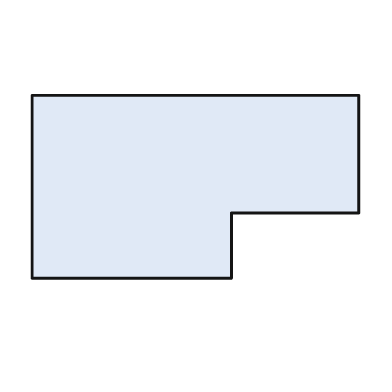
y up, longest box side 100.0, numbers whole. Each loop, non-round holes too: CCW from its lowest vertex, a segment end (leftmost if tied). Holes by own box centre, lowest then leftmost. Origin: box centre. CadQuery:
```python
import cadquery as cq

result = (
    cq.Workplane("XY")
    .moveTo(-50.0, -28.0)
    .lineTo(11.0, -28.0)
    .lineTo(11.0, -8.0)
    .lineTo(50.0, -8.0)
    .lineTo(50.0, 28.0)
    .lineTo(-50.0, 28.0)
    .close()
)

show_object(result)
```